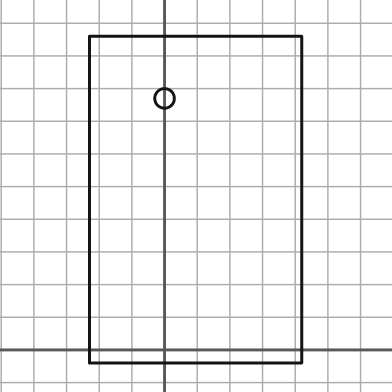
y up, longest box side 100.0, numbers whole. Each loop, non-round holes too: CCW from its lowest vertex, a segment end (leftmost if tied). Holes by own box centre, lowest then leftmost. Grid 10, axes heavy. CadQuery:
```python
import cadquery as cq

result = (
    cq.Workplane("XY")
    .moveTo(-23.0, -4.0)
    .lineTo(42.0, -4.0)
    .lineTo(42.0, 96.0)
    .lineTo(-23.0, 96.0)
    .close()
    .moveTo(0.0, 77.0)
    .circle(3.0)
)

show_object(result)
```